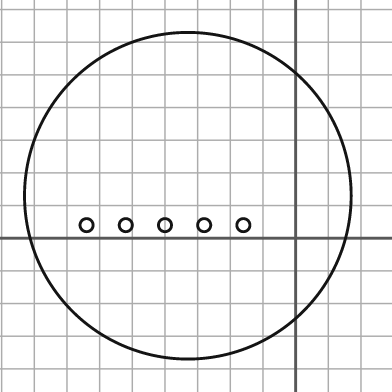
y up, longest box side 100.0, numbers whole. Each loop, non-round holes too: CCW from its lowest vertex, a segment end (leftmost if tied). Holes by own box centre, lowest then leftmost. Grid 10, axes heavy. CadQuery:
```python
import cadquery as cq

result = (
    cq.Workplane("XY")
    .moveTo(-33.0, 13.0)
    .circle(50.0)
    .moveTo(-64.0, 4.0)
    .circle(2.0)
    .moveTo(-52.0, 4.0)
    .circle(2.0)
    .moveTo(-40.0, 4.0)
    .circle(2.0)
    .moveTo(-28.0, 4.0)
    .circle(2.0)
    .moveTo(-16.0, 4.0)
    .circle(2.0)
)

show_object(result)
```